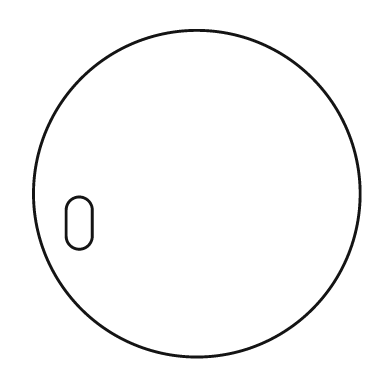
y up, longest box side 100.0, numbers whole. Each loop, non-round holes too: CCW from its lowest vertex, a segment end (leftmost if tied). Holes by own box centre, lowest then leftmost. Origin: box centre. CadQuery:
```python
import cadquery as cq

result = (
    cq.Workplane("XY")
    .moveTo(0.0, 0.0)
    .circle(50.0)
    .moveTo(-40.0, -13.0)
    .threePointArc((-36.0, -17.0), (-32.0, -13.0))
    .lineTo(-32.0, -5.0)
    .threePointArc((-36.0, -1.0), (-40.0, -5.0))
    .close()
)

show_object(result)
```